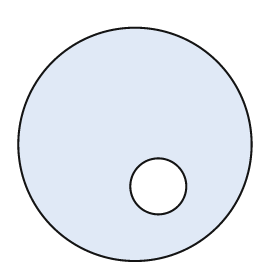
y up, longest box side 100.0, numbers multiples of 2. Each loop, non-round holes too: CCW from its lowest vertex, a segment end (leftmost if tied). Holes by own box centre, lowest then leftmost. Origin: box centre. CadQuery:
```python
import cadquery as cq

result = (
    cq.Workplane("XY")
    .moveTo(0.0, 0.0)
    .circle(50.0)
    .moveTo(10.0, -18.0)
    .circle(12.0)
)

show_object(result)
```